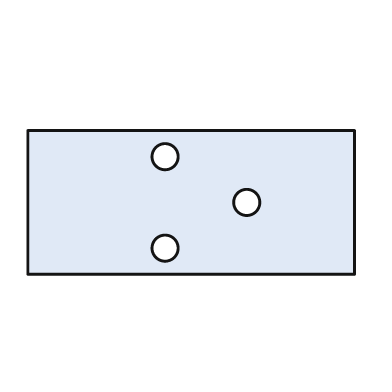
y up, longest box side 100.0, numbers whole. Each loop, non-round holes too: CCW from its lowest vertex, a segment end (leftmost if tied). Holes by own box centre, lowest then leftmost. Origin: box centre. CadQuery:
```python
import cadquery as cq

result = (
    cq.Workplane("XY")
    .moveTo(-50.0, -22.0)
    .lineTo(50.0, -22.0)
    .lineTo(50.0, 22.0)
    .lineTo(-50.0, 22.0)
    .close()
    .moveTo(-8.0, -14.0)
    .circle(4.0)
    .moveTo(17.0, 0.0)
    .circle(4.0)
    .moveTo(-8.0, 14.0)
    .circle(4.0)
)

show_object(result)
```